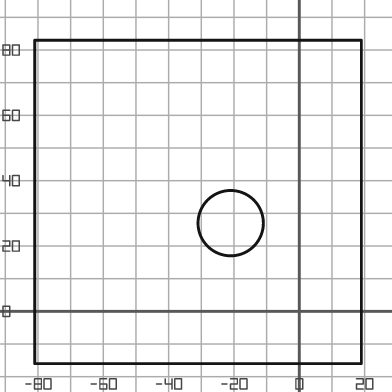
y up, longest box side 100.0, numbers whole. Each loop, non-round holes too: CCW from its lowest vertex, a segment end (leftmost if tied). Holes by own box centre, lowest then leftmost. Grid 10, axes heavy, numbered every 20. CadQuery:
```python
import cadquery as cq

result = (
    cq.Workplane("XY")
    .moveTo(-81.0, -16.0)
    .lineTo(19.0, -16.0)
    .lineTo(19.0, 83.0)
    .lineTo(-81.0, 83.0)
    .close()
    .moveTo(-21.0, 27.0)
    .circle(10.0)
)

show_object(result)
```